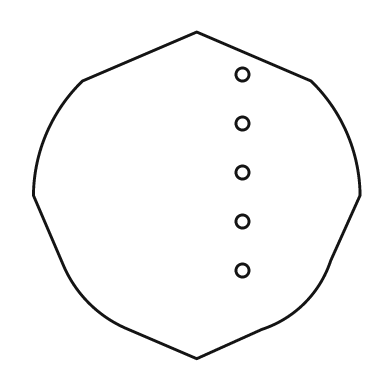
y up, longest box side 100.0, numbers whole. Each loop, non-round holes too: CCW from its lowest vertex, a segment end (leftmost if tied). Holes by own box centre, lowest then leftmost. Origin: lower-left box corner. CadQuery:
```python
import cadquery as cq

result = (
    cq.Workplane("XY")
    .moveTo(50.0, 0.0)
    .lineTo(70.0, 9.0)
    .threePointArc((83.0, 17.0), (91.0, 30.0))
    .lineTo(100.0, 50.0)
    .threePointArc((96.0, 69.0), (85.0, 85.0))
    .lineTo(50.0, 100.0)
    .lineTo(15.0, 85.0)
    .threePointArc((4.0, 69.0), (0.0, 50.0))
    .lineTo(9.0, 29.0)
    .threePointArc((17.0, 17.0), (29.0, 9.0))
    .close()
    .moveTo(64.0, 27.0)
    .circle(2.0)
    .moveTo(64.0, 42.0)
    .circle(2.0)
    .moveTo(64.0, 57.0)
    .circle(2.0)
    .moveTo(64.0, 72.0)
    .circle(2.0)
    .moveTo(64.0, 87.0)
    .circle(2.0)
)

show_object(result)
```